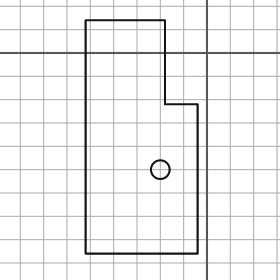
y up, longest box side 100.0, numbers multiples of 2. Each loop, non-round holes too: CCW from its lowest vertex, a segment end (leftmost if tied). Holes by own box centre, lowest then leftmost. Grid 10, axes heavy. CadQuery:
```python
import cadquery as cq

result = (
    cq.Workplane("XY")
    .moveTo(-52.0, -86.0)
    .lineTo(-4.0, -86.0)
    .lineTo(-4.0, -22.0)
    .lineTo(-18.0, -22.0)
    .lineTo(-18.0, 14.0)
    .lineTo(-52.0, 14.0)
    .close()
    .moveTo(-20.0, -50.0)
    .circle(4.0)
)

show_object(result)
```